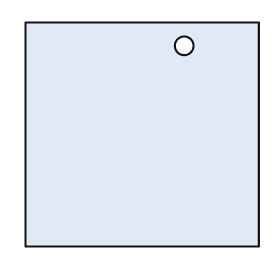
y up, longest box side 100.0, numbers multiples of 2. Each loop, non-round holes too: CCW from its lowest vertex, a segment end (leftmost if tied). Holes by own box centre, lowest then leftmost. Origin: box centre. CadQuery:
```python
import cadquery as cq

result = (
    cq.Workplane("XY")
    .moveTo(-50.0, -48.0)
    .lineTo(50.0, -48.0)
    .lineTo(50.0, 48.0)
    .lineTo(-50.0, 48.0)
    .close()
    .moveTo(18.0, 38.0)
    .circle(4.0)
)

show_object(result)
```